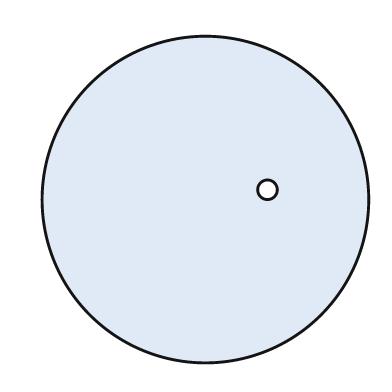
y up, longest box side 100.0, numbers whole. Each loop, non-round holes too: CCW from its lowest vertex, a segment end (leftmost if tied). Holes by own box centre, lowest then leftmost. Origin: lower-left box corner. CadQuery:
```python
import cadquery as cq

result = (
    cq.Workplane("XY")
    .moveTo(50.0, 50.0)
    .circle(50.0)
    .moveTo(69.0, 53.0)
    .circle(3.0)
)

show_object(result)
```